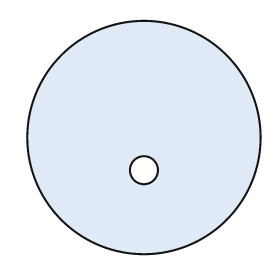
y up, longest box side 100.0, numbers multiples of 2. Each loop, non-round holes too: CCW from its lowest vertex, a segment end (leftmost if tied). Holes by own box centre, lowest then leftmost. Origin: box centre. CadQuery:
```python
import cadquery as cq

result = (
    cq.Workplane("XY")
    .moveTo(0.0, 0.0)
    .circle(50.0)
    .moveTo(0.0, -14.0)
    .circle(6.0)
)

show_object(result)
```